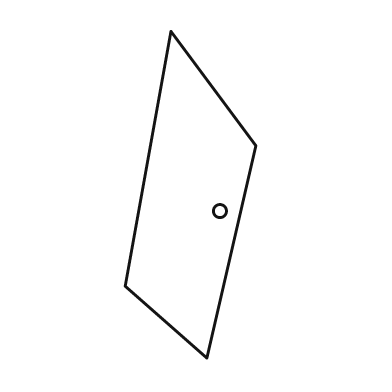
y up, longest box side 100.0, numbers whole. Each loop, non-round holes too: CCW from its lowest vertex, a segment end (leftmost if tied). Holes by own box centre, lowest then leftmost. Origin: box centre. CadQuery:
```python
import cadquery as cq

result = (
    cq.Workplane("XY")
    .moveTo(5.0, -50.0)
    .lineTo(20.0, 15.0)
    .lineTo(-6.0, 50.0)
    .lineTo(-20.0, -28.0)
    .close()
    .moveTo(9.0, -5.0)
    .circle(2.0)
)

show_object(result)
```